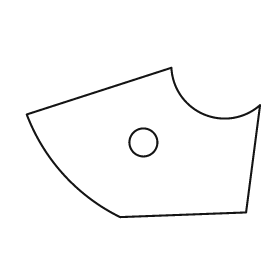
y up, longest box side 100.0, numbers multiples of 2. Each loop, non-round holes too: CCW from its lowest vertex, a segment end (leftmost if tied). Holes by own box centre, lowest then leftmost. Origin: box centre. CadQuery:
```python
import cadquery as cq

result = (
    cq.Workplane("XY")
    .moveTo(-10.0, -32.0)
    .lineTo(44.0, -30.0)
    .lineTo(50.0, 16.0)
    .threePointArc((26.0, 12.0), (12.0, 32.0))
    .lineTo(-50.0, 12.0)
    .threePointArc((-34.0, -14.0), (-10.0, -32.0))
    .close()
    .moveTo(0.0, 0.0)
    .circle(6.0)
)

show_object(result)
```